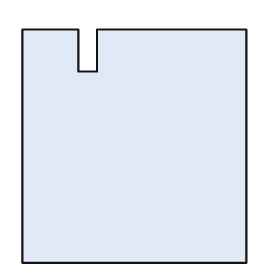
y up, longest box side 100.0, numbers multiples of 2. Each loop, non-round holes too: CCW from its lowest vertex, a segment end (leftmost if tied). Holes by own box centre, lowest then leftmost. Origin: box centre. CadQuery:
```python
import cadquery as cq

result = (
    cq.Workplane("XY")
    .moveTo(-48.0, -50.0)
    .lineTo(48.0, -50.0)
    .lineTo(48.0, 50.0)
    .lineTo(-16.0, 50.0)
    .lineTo(-16.0, 32.0)
    .lineTo(-24.0, 32.0)
    .lineTo(-24.0, 50.0)
    .lineTo(-48.0, 50.0)
    .close()
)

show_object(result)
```